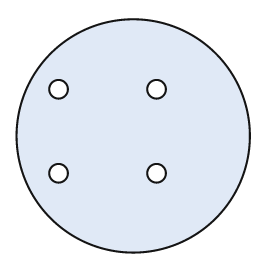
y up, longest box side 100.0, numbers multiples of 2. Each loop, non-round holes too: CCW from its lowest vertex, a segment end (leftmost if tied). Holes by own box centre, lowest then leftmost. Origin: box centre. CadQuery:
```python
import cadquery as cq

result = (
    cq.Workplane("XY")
    .moveTo(0.0, 0.0)
    .circle(50.0)
    .moveTo(-32.0, -16.0)
    .circle(4.0)
    .moveTo(10.0, -16.0)
    .circle(4.0)
    .moveTo(-32.0, 20.0)
    .circle(4.0)
    .moveTo(10.0, 20.0)
    .circle(4.0)
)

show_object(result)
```